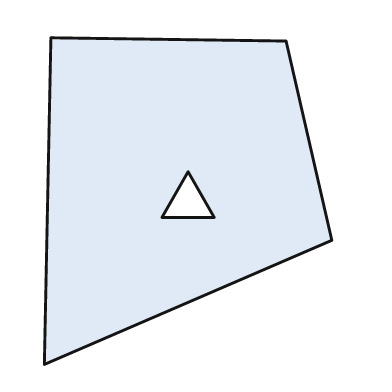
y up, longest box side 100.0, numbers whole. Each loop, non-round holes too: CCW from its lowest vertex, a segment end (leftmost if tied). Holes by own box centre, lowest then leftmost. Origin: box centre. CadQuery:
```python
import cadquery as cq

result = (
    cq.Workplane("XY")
    .moveTo(-44.0, -50.0)
    .lineTo(44.0, -12.0)
    .lineTo(30.0, 49.0)
    .lineTo(-42.0, 50.0)
    .close()
    .moveTo(-8.0, -5.0)
    .lineTo(8.0, -5.0)
    .lineTo(0.0, 9.0)
    .close()
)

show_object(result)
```